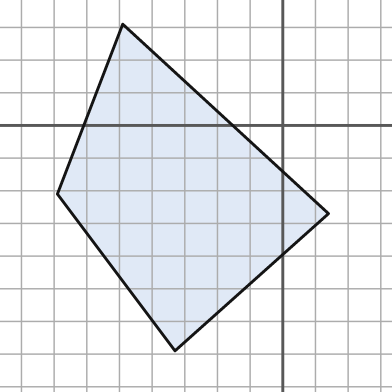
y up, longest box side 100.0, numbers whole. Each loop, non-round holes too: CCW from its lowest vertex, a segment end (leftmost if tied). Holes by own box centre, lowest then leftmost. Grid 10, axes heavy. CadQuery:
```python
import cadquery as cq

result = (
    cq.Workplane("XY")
    .moveTo(-33.0, -69.0)
    .lineTo(14.0, -27.0)
    .lineTo(-49.0, 31.0)
    .lineTo(-69.0, -21.0)
    .close()
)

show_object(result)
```